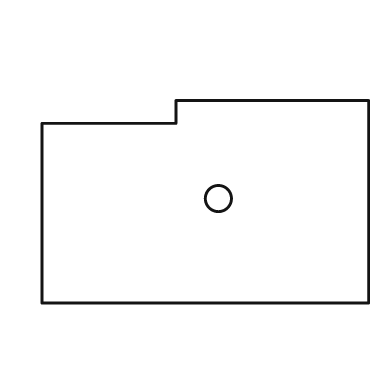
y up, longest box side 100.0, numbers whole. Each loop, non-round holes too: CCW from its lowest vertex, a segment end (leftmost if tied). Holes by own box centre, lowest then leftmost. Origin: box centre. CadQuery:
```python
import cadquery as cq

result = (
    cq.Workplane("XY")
    .moveTo(-50.0, -31.0)
    .lineTo(50.0, -31.0)
    .lineTo(50.0, 31.0)
    .lineTo(-9.0, 31.0)
    .lineTo(-9.0, 24.0)
    .lineTo(-50.0, 24.0)
    .close()
    .moveTo(4.0, 1.0)
    .circle(4.0)
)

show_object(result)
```